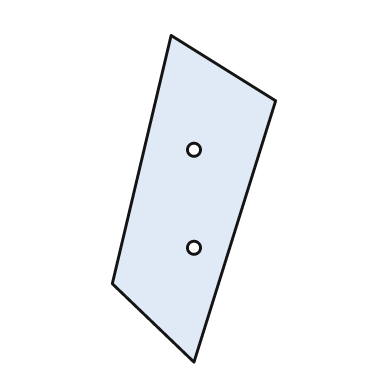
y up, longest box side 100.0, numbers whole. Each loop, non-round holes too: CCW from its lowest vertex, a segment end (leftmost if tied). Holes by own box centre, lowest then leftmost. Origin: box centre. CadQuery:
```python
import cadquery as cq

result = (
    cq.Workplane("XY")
    .moveTo(0.0, -50.0)
    .lineTo(25.0, 30.0)
    .lineTo(-7.0, 50.0)
    .lineTo(-25.0, -26.0)
    .close()
    .moveTo(0.0, -15.0)
    .circle(2.0)
    .moveTo(0.0, 15.0)
    .circle(2.0)
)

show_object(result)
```